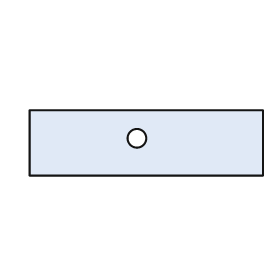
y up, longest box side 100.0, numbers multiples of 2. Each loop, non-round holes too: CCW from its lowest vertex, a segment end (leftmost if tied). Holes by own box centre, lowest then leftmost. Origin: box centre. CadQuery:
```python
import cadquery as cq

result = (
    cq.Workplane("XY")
    .moveTo(-50.0, -14.0)
    .lineTo(50.0, -14.0)
    .lineTo(50.0, 14.0)
    .lineTo(-50.0, 14.0)
    .close()
    .moveTo(-4.0, 2.0)
    .circle(4.0)
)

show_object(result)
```